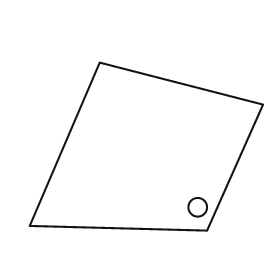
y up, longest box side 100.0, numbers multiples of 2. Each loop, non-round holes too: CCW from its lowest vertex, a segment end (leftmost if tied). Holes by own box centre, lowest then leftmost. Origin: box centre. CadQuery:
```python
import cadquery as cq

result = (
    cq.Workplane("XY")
    .moveTo(26.0, -36.0)
    .lineTo(50.0, 18.0)
    .lineTo(-20.0, 36.0)
    .lineTo(-50.0, -34.0)
    .close()
    .moveTo(22.0, -26.0)
    .circle(4.0)
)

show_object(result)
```